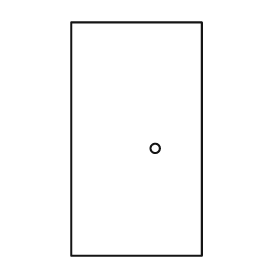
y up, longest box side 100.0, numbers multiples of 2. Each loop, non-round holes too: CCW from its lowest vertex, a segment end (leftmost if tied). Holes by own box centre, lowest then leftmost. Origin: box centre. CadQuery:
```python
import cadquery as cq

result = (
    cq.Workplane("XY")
    .moveTo(-28.0, -50.0)
    .lineTo(28.0, -50.0)
    .lineTo(28.0, 50.0)
    .lineTo(-28.0, 50.0)
    .close()
    .moveTo(8.0, -4.0)
    .circle(2.0)
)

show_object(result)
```